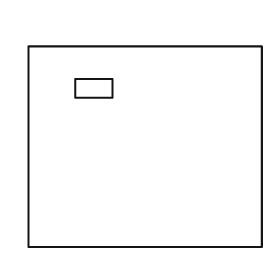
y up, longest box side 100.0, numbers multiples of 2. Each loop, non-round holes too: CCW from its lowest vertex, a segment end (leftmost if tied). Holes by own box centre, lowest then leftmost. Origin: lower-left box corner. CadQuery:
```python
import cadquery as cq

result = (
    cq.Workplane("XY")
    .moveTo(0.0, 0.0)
    .lineTo(100.0, 0.0)
    .lineTo(100.0, 86.0)
    .lineTo(0.0, 86.0)
    .close()
    .moveTo(20.0, 64.0)
    .lineTo(36.0, 64.0)
    .lineTo(36.0, 72.0)
    .lineTo(20.0, 72.0)
    .close()
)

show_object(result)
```